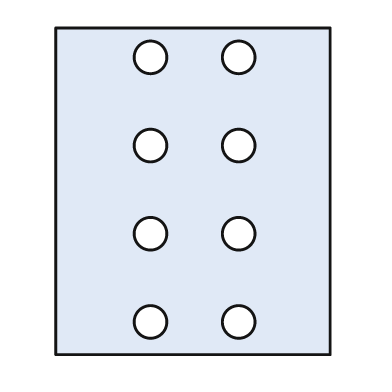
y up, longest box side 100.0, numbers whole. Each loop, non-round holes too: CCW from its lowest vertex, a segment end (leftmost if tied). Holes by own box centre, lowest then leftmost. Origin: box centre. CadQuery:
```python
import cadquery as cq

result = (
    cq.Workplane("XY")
    .moveTo(-42.0, -50.0)
    .lineTo(42.0, -50.0)
    .lineTo(42.0, 50.0)
    .lineTo(-42.0, 50.0)
    .close()
    .moveTo(-13.0, -40.0)
    .circle(5.0)
    .moveTo(14.0, -40.0)
    .circle(5.0)
    .moveTo(-13.0, -13.0)
    .circle(5.0)
    .moveTo(14.0, -13.0)
    .circle(5.0)
    .moveTo(-13.0, 14.0)
    .circle(5.0)
    .moveTo(14.0, 14.0)
    .circle(5.0)
    .moveTo(-13.0, 41.0)
    .circle(5.0)
    .moveTo(14.0, 41.0)
    .circle(5.0)
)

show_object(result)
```